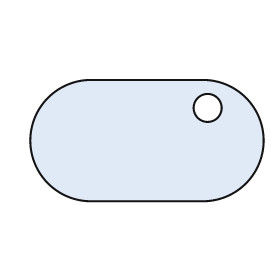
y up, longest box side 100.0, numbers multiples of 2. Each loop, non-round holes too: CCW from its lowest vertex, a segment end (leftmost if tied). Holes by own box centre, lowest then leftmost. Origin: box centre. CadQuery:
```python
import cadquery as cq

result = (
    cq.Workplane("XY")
    .moveTo(-24.0, -26.0)
    .lineTo(24.0, -26.0)
    .threePointArc((50.0, 0.0), (24.0, 26.0))
    .lineTo(-24.0, 26.0)
    .threePointArc((-50.0, 0.0), (-24.0, -26.0))
    .close()
    .moveTo(26.0, 14.0)
    .circle(6.0)
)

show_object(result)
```